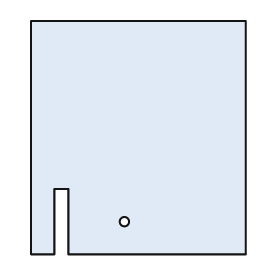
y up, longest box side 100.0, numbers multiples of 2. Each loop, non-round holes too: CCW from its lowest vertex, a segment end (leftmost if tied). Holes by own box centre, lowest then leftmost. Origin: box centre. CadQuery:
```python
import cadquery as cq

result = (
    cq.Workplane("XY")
    .moveTo(-46.0, -50.0)
    .lineTo(-36.0, -50.0)
    .lineTo(-36.0, -22.0)
    .lineTo(-30.0, -22.0)
    .lineTo(-30.0, -50.0)
    .lineTo(46.0, -50.0)
    .lineTo(46.0, 50.0)
    .lineTo(-46.0, 50.0)
    .close()
    .moveTo(-6.0, -36.0)
    .circle(2.0)
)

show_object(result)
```